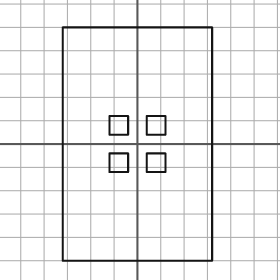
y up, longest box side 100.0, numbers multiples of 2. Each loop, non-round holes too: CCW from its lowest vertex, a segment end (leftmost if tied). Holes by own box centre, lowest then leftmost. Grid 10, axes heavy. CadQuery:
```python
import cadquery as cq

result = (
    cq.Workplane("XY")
    .moveTo(-32.0, -50.0)
    .lineTo(32.0, -50.0)
    .lineTo(32.0, 50.0)
    .lineTo(-32.0, 50.0)
    .close()
    .moveTo(-12.0, -12.0)
    .lineTo(-4.0, -12.0)
    .lineTo(-4.0, -4.0)
    .lineTo(-12.0, -4.0)
    .close()
    .moveTo(4.0, -12.0)
    .lineTo(12.0, -12.0)
    .lineTo(12.0, -4.0)
    .lineTo(4.0, -4.0)
    .close()
    .moveTo(-12.0, 4.0)
    .lineTo(-4.0, 4.0)
    .lineTo(-4.0, 12.0)
    .lineTo(-12.0, 12.0)
    .close()
    .moveTo(4.0, 4.0)
    .lineTo(12.0, 4.0)
    .lineTo(12.0, 12.0)
    .lineTo(4.0, 12.0)
    .close()
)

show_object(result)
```